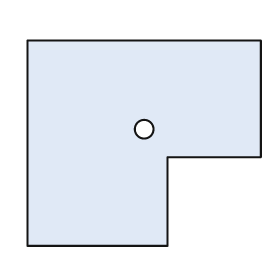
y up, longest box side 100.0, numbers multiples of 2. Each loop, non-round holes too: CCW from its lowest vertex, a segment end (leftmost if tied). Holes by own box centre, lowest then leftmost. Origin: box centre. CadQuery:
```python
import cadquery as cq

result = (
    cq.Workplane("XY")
    .moveTo(-50.0, -44.0)
    .lineTo(10.0, -44.0)
    .lineTo(10.0, -6.0)
    .lineTo(50.0, -6.0)
    .lineTo(50.0, 44.0)
    .lineTo(-50.0, 44.0)
    .close()
    .moveTo(0.0, 6.0)
    .circle(4.0)
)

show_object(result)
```